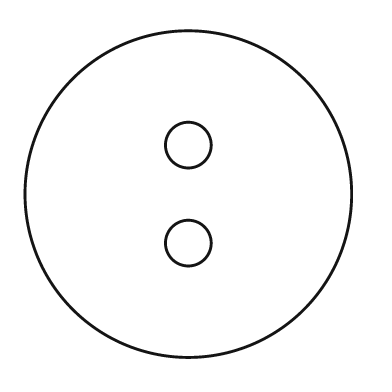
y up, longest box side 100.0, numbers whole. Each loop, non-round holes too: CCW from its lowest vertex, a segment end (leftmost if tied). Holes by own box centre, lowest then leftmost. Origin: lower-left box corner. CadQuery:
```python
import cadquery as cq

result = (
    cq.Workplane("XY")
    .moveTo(50.0, 50.0)
    .circle(50.0)
    .moveTo(50.0, 35.0)
    .circle(7.0)
    .moveTo(50.0, 65.0)
    .circle(7.0)
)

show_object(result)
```